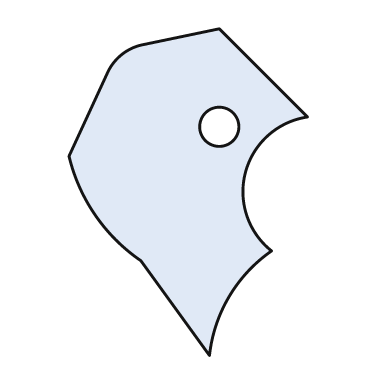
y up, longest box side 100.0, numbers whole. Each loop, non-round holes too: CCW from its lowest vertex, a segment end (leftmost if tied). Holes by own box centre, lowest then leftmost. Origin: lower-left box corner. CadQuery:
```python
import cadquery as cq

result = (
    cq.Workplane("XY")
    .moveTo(43.0, 0.0)
    .threePointArc((49.0, 18.0), (62.0, 32.0))
    .threePointArc((54.0, 56.0), (73.0, 73.0))
    .lineTo(46.0, 100.0)
    .lineTo(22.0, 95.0)
    .threePointArc((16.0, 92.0), (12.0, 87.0))
    .lineTo(0.0, 61.0)
    .threePointArc((8.0, 43.0), (22.0, 29.0))
    .close()
    .moveTo(46.0, 70.0)
    .circle(6.0)
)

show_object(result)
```